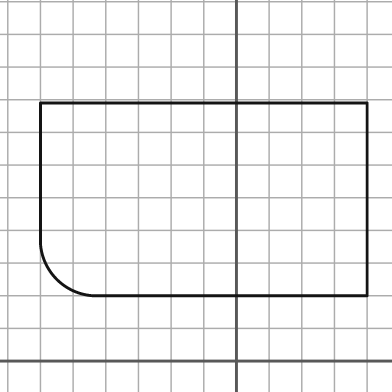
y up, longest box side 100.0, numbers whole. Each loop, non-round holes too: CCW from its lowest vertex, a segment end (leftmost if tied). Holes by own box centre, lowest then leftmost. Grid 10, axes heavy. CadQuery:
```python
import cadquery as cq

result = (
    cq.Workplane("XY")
    .moveTo(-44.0, 20.0)
    .lineTo(40.0, 20.0)
    .lineTo(40.0, 79.0)
    .lineTo(-60.0, 79.0)
    .lineTo(-60.0, 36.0)
    .threePointArc((-55.0, 25.0), (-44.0, 20.0))
    .close()
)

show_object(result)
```